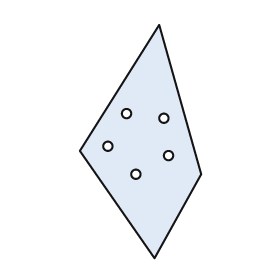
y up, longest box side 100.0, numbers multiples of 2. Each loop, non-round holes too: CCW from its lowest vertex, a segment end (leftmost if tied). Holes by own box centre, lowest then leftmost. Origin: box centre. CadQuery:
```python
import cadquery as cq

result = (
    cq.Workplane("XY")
    .moveTo(6.0, -50.0)
    .lineTo(26.0, -14.0)
    .lineTo(8.0, 50.0)
    .lineTo(-26.0, -4.0)
    .close()
    .moveTo(-2.0, -14.0)
    .circle(2.0)
    .moveTo(12.0, -6.0)
    .circle(2.0)
    .moveTo(-14.0, -2.0)
    .circle(2.0)
    .moveTo(10.0, 10.0)
    .circle(2.0)
    .moveTo(-6.0, 12.0)
    .circle(2.0)
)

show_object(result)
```